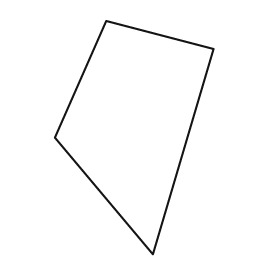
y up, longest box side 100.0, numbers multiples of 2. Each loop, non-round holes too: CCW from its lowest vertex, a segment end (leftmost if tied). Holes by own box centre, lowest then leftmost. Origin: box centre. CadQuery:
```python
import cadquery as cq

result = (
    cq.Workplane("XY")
    .moveTo(8.0, -50.0)
    .lineTo(34.0, 38.0)
    .lineTo(-12.0, 50.0)
    .lineTo(-34.0, 0.0)
    .close()
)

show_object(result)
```